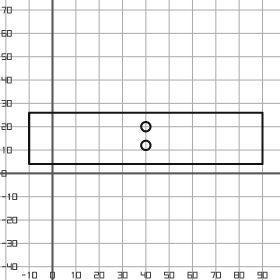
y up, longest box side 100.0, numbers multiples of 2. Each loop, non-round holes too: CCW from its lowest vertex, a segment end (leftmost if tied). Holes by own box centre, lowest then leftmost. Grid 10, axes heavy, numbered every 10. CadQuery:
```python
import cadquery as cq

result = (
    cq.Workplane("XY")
    .moveTo(-10.0, 4.0)
    .lineTo(90.0, 4.0)
    .lineTo(90.0, 26.0)
    .lineTo(-10.0, 26.0)
    .close()
    .moveTo(40.0, 12.0)
    .circle(2.0)
    .moveTo(40.0, 20.0)
    .circle(2.0)
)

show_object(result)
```